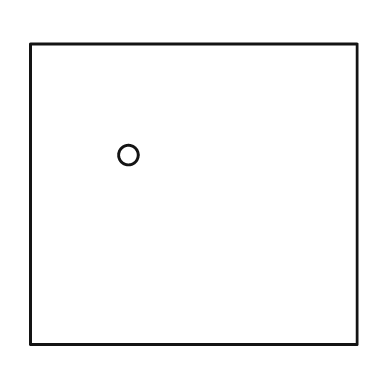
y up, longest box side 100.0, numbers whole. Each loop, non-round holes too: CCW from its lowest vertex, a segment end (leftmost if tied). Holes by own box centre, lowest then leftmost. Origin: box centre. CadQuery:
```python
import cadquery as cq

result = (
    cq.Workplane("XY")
    .moveTo(-50.0, -46.0)
    .lineTo(50.0, -46.0)
    .lineTo(50.0, 46.0)
    .lineTo(-50.0, 46.0)
    .close()
    .moveTo(-20.0, 12.0)
    .circle(3.0)
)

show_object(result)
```